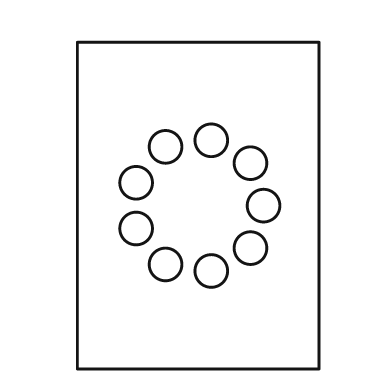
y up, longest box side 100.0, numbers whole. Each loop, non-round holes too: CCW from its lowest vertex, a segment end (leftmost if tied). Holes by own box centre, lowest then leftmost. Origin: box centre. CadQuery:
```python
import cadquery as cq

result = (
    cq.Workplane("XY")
    .moveTo(-37.0, -50.0)
    .lineTo(37.0, -50.0)
    .lineTo(37.0, 50.0)
    .lineTo(-37.0, 50.0)
    .close()
    .moveTo(4.0, -20.0)
    .circle(5.0)
    .moveTo(-10.0, -18.0)
    .circle(5.0)
    .moveTo(16.0, -13.0)
    .circle(5.0)
    .moveTo(-19.0, -7.0)
    .circle(5.0)
    .moveTo(20.0, 0.0)
    .circle(5.0)
    .moveTo(-19.0, 7.0)
    .circle(5.0)
    .moveTo(16.0, 13.0)
    .circle(5.0)
    .moveTo(-10.0, 18.0)
    .circle(5.0)
    .moveTo(4.0, 20.0)
    .circle(5.0)
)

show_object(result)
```